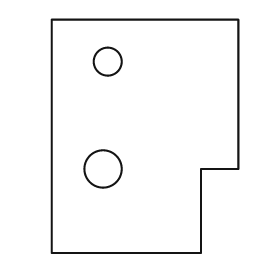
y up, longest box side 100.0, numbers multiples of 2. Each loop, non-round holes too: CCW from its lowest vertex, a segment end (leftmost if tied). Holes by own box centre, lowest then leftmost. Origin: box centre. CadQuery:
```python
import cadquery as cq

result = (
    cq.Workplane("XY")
    .moveTo(-40.0, -50.0)
    .lineTo(24.0, -50.0)
    .lineTo(24.0, -14.0)
    .lineTo(40.0, -14.0)
    .lineTo(40.0, 50.0)
    .lineTo(-40.0, 50.0)
    .close()
    .moveTo(-18.0, -14.0)
    .circle(8.0)
    .moveTo(-16.0, 32.0)
    .circle(6.0)
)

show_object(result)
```